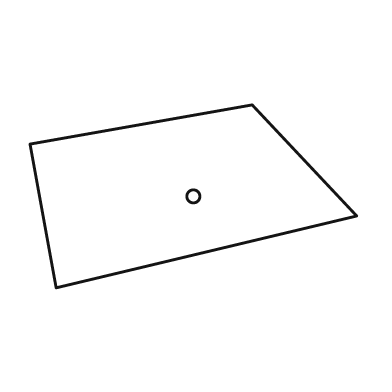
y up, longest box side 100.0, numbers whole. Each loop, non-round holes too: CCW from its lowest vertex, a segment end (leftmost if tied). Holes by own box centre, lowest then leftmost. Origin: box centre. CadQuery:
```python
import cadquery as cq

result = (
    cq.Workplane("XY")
    .moveTo(-42.0, -28.0)
    .lineTo(50.0, -6.0)
    .lineTo(18.0, 28.0)
    .lineTo(-50.0, 16.0)
    .close()
    .moveTo(0.0, 0.0)
    .circle(2.0)
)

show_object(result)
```